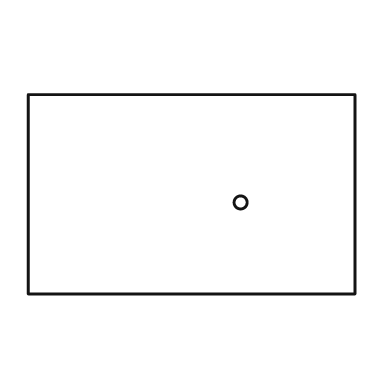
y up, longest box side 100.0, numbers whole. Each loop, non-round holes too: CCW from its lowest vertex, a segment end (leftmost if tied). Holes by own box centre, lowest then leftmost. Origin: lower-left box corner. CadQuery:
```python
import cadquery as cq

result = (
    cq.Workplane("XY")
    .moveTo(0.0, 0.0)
    .lineTo(100.0, 0.0)
    .lineTo(100.0, 61.0)
    .lineTo(0.0, 61.0)
    .close()
    .moveTo(65.0, 28.0)
    .circle(2.0)
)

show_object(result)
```